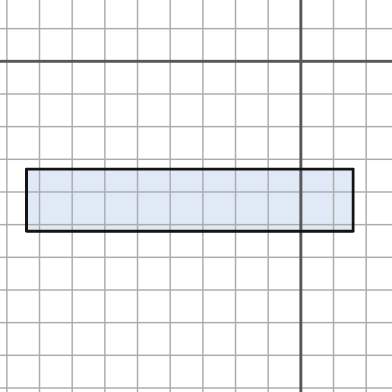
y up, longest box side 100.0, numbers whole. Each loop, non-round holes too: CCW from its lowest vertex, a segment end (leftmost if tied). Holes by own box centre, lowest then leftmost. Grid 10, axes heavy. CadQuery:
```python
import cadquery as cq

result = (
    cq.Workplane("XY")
    .moveTo(-84.0, -52.0)
    .lineTo(16.0, -52.0)
    .lineTo(16.0, -33.0)
    .lineTo(-84.0, -33.0)
    .close()
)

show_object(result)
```